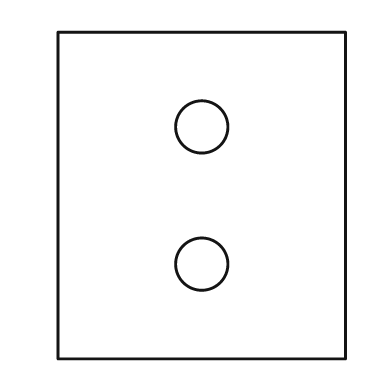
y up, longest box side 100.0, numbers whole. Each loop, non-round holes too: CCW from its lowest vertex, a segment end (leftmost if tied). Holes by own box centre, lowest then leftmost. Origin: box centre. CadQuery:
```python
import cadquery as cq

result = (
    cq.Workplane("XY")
    .moveTo(-44.0, -50.0)
    .lineTo(44.0, -50.0)
    .lineTo(44.0, 50.0)
    .lineTo(-44.0, 50.0)
    .close()
    .moveTo(0.0, -21.0)
    .circle(8.0)
    .moveTo(0.0, 21.0)
    .circle(8.0)
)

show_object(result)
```